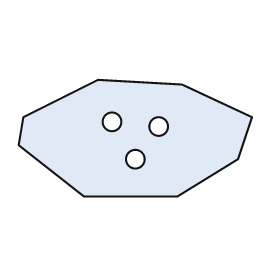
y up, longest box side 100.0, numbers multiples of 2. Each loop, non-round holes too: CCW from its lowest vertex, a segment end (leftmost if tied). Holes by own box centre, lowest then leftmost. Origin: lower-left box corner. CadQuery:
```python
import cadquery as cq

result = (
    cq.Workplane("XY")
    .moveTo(28.0, 0.0)
    .lineTo(68.0, 0.0)
    .lineTo(94.0, 16.0)
    .lineTo(100.0, 34.0)
    .lineTo(70.0, 48.0)
    .lineTo(34.0, 50.0)
    .lineTo(2.0, 34.0)
    .lineTo(0.0, 22.0)
    .close()
    .moveTo(50.0, 16.0)
    .circle(4.0)
    .moveTo(60.0, 30.0)
    .circle(4.0)
    .moveTo(40.0, 32.0)
    .circle(4.0)
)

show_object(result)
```